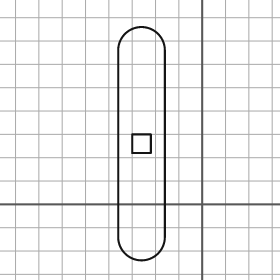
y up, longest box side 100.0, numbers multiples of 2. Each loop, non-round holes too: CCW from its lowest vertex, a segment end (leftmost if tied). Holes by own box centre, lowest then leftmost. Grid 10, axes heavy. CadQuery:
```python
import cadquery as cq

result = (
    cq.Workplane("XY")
    .moveTo(-36.0, -14.0)
    .threePointArc((-26.0, -24.0), (-16.0, -14.0))
    .lineTo(-16.0, 66.0)
    .threePointArc((-26.0, 76.0), (-36.0, 66.0))
    .close()
    .moveTo(-30.0, 22.0)
    .lineTo(-22.0, 22.0)
    .lineTo(-22.0, 30.0)
    .lineTo(-30.0, 30.0)
    .close()
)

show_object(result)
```